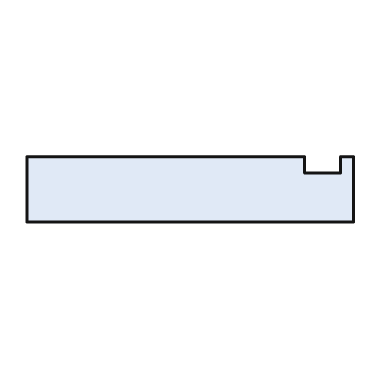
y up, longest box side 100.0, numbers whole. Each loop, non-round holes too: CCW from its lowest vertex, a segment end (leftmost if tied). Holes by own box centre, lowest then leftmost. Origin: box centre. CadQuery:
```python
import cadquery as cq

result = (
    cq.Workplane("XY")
    .moveTo(-50.0, -10.0)
    .lineTo(50.0, -10.0)
    .lineTo(50.0, 10.0)
    .lineTo(46.0, 10.0)
    .lineTo(46.0, 5.0)
    .lineTo(35.0, 5.0)
    .lineTo(35.0, 10.0)
    .lineTo(-50.0, 10.0)
    .close()
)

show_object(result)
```